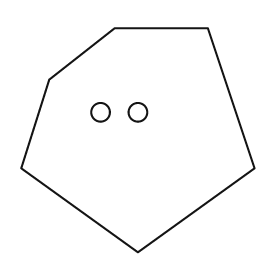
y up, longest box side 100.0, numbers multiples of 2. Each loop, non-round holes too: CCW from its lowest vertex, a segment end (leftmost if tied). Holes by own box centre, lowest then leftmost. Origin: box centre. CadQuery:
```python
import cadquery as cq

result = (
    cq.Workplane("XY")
    .moveTo(0.0, -48.0)
    .lineTo(50.0, -12.0)
    .lineTo(30.0, 48.0)
    .lineTo(-10.0, 48.0)
    .lineTo(-38.0, 26.0)
    .lineTo(-50.0, -12.0)
    .close()
    .moveTo(-16.0, 12.0)
    .circle(4.0)
    .moveTo(0.0, 12.0)
    .circle(4.0)
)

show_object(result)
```